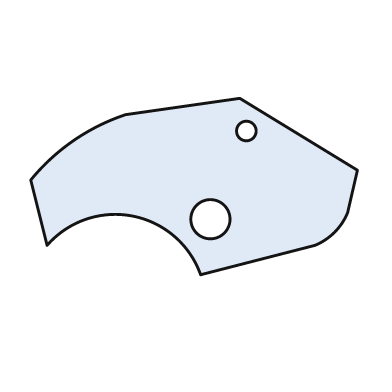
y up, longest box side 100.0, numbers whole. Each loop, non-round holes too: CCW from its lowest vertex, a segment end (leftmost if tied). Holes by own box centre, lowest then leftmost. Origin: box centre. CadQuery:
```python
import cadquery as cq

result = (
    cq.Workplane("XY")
    .moveTo(2.0, -27.0)
    .lineTo(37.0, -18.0)
    .threePointArc((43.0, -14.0), (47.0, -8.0))
    .lineTo(50.0, 5.0)
    .lineTo(14.0, 27.0)
    .lineTo(-21.0, 22.0)
    .threePointArc((-37.0, 14.0), (-50.0, 2.0))
    .lineTo(-45.0, -18.0)
    .threePointArc((-19.0, -9.0), (2.0, -27.0))
    .close()
    .moveTo(5.0, -10.0)
    .circle(6.0)
    .moveTo(16.0, 17.0)
    .circle(3.0)
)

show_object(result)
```